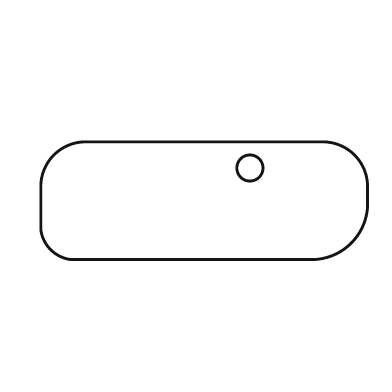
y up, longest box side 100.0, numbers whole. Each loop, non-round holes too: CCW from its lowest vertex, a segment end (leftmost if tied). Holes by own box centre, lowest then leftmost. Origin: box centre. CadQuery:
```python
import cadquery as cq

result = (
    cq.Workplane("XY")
    .moveTo(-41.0, -18.0)
    .lineTo(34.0, -18.0)
    .threePointArc((45.0, -13.0), (50.0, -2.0))
    .lineTo(50.0, 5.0)
    .threePointArc((46.0, 14.0), (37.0, 18.0))
    .lineTo(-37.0, 18.0)
    .threePointArc((-46.0, 14.0), (-50.0, 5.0))
    .lineTo(-50.0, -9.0)
    .threePointArc((-47.0, -15.0), (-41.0, -18.0))
    .close()
    .moveTo(14.0, 10.0)
    .circle(4.0)
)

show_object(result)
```